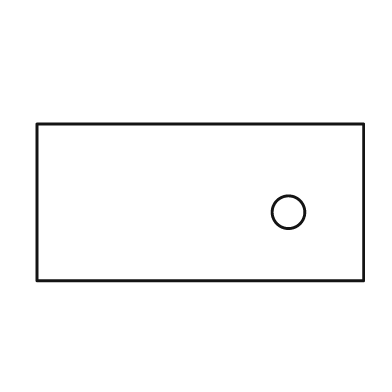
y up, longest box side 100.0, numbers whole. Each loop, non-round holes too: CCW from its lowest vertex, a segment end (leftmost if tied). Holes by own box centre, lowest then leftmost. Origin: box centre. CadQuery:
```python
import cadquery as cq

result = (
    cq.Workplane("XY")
    .moveTo(-50.0, -24.0)
    .lineTo(50.0, -24.0)
    .lineTo(50.0, 24.0)
    .lineTo(-50.0, 24.0)
    .close()
    .moveTo(27.0, -3.0)
    .circle(5.0)
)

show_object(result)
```